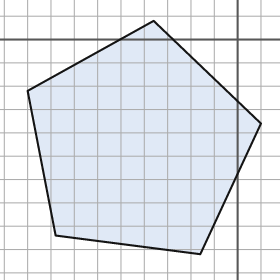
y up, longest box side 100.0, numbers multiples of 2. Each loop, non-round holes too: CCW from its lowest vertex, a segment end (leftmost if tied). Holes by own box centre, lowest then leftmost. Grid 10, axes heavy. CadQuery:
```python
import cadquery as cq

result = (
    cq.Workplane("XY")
    .moveTo(-16.0, -92.0)
    .lineTo(10.0, -36.0)
    .lineTo(-36.0, 8.0)
    .lineTo(-90.0, -22.0)
    .lineTo(-78.0, -84.0)
    .close()
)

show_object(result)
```